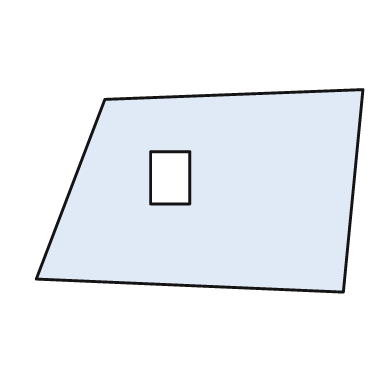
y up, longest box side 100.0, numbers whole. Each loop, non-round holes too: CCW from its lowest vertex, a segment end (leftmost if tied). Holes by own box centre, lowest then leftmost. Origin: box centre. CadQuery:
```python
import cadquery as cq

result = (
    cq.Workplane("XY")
    .moveTo(44.0, -31.0)
    .lineTo(50.0, 31.0)
    .lineTo(-29.0, 28.0)
    .lineTo(-50.0, -27.0)
    .close()
    .moveTo(-15.0, -4.0)
    .lineTo(-3.0, -4.0)
    .lineTo(-3.0, 12.0)
    .lineTo(-15.0, 12.0)
    .close()
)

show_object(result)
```